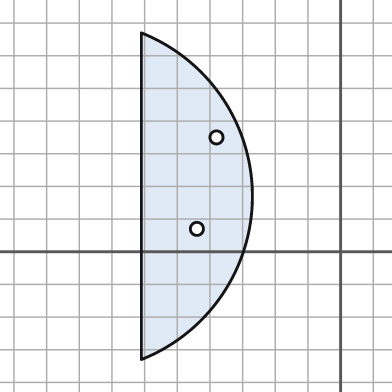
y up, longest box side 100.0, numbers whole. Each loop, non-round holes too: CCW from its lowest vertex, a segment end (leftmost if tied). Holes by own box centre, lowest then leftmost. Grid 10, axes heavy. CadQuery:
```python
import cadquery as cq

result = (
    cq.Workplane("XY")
    .moveTo(-61.0, -33.0)
    .threePointArc((-27.0, 17.0), (-61.0, 67.0))
    .close()
    .moveTo(-44.0, 7.0)
    .circle(2.0)
    .moveTo(-38.0, 35.0)
    .circle(2.0)
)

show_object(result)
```